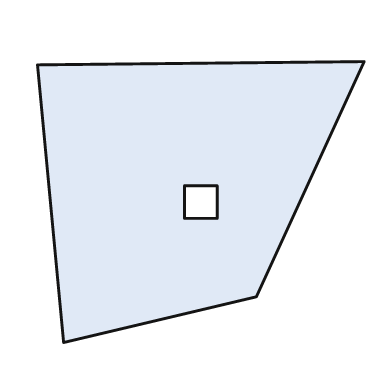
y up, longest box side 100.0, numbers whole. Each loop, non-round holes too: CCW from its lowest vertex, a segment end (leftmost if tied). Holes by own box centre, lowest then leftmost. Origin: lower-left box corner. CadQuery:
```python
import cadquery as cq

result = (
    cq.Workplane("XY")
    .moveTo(8.0, 0.0)
    .lineTo(67.0, 14.0)
    .lineTo(100.0, 86.0)
    .lineTo(0.0, 85.0)
    .close()
    .moveTo(45.0, 38.0)
    .lineTo(55.0, 38.0)
    .lineTo(55.0, 48.0)
    .lineTo(45.0, 48.0)
    .close()
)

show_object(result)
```